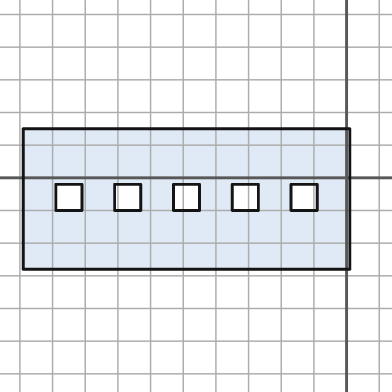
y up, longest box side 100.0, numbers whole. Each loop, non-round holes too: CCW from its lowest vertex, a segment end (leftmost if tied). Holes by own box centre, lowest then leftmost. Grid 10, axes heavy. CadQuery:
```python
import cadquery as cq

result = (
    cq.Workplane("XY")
    .moveTo(-99.0, -28.0)
    .lineTo(1.0, -28.0)
    .lineTo(1.0, 15.0)
    .lineTo(-99.0, 15.0)
    .close()
    .moveTo(-89.0, -10.0)
    .lineTo(-81.0, -10.0)
    .lineTo(-81.0, -2.0)
    .lineTo(-89.0, -2.0)
    .close()
    .moveTo(-71.0, -10.0)
    .lineTo(-63.0, -10.0)
    .lineTo(-63.0, -2.0)
    .lineTo(-71.0, -2.0)
    .close()
    .moveTo(-53.0, -10.0)
    .lineTo(-45.0, -10.0)
    .lineTo(-45.0, -2.0)
    .lineTo(-53.0, -2.0)
    .close()
    .moveTo(-35.0, -10.0)
    .lineTo(-27.0, -10.0)
    .lineTo(-27.0, -2.0)
    .lineTo(-35.0, -2.0)
    .close()
    .moveTo(-17.0, -10.0)
    .lineTo(-9.0, -10.0)
    .lineTo(-9.0, -2.0)
    .lineTo(-17.0, -2.0)
    .close()
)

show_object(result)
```